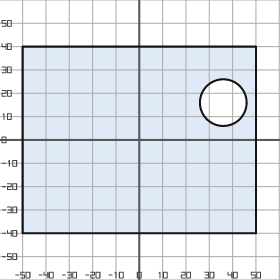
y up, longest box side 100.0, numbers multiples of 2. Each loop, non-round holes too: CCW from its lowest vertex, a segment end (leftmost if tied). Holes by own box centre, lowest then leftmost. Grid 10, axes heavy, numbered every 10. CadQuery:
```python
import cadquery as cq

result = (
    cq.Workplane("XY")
    .moveTo(-50.0, -40.0)
    .lineTo(50.0, -40.0)
    .lineTo(50.0, 40.0)
    .lineTo(-50.0, 40.0)
    .close()
    .moveTo(36.0, 16.0)
    .circle(10.0)
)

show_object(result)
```